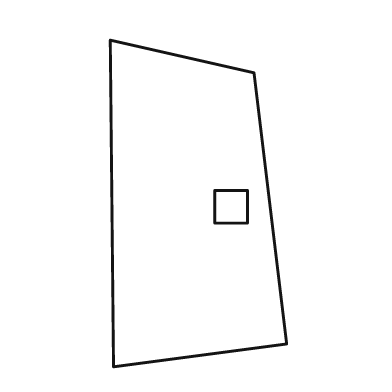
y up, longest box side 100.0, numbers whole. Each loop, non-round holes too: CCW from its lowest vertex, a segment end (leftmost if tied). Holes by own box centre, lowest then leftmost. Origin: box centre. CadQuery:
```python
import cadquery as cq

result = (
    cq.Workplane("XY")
    .moveTo(-26.0, -50.0)
    .lineTo(27.0, -43.0)
    .lineTo(17.0, 40.0)
    .lineTo(-27.0, 50.0)
    .close()
    .moveTo(5.0, -6.0)
    .lineTo(15.0, -6.0)
    .lineTo(15.0, 4.0)
    .lineTo(5.0, 4.0)
    .close()
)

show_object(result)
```